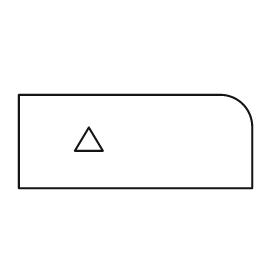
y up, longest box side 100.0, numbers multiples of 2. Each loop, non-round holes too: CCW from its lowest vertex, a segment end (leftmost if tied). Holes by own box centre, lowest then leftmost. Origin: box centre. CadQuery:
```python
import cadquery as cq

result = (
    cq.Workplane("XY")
    .moveTo(-50.0, -20.0)
    .lineTo(50.0, -20.0)
    .lineTo(50.0, 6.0)
    .threePointArc((46.0, 16.0), (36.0, 20.0))
    .lineTo(-50.0, 20.0)
    .close()
    .moveTo(-26.0, -4.0)
    .lineTo(-14.0, -4.0)
    .lineTo(-20.0, 6.0)
    .close()
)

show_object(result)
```